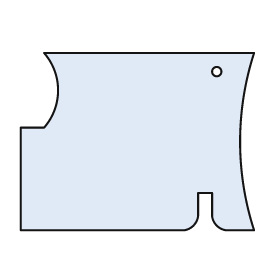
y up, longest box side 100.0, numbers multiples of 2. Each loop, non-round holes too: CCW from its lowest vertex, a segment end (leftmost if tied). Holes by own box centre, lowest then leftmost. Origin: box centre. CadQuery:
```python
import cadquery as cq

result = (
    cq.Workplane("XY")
    .moveTo(-50.0, -38.0)
    .lineTo(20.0, -38.0)
    .threePointArc((24.0, -36.0), (26.0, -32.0))
    .lineTo(26.0, -22.0)
    .lineTo(32.0, -22.0)
    .lineTo(32.0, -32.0)
    .threePointArc((34.0, -36.0), (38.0, -38.0))
    .lineTo(50.0, -38.0)
    .threePointArc((44.0, 0.0), (50.0, 38.0))
    .lineTo(-40.0, 38.0)
    .threePointArc((-34.0, 22.0), (-40.0, 6.0))
    .lineTo(-50.0, 6.0)
    .close()
    .moveTo(34.0, 30.0)
    .circle(2.0)
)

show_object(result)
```